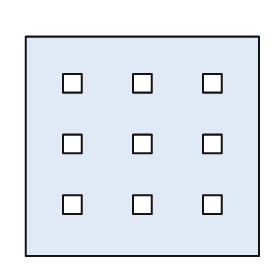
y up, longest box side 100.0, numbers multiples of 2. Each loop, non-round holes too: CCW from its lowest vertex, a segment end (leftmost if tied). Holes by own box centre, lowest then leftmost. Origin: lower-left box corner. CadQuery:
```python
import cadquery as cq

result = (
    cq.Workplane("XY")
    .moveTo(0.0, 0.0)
    .lineTo(100.0, 0.0)
    .lineTo(100.0, 94.0)
    .lineTo(0.0, 94.0)
    .close()
    .moveTo(16.0, 18.0)
    .lineTo(24.0, 18.0)
    .lineTo(24.0, 26.0)
    .lineTo(16.0, 26.0)
    .close()
    .moveTo(46.0, 18.0)
    .lineTo(54.0, 18.0)
    .lineTo(54.0, 26.0)
    .lineTo(46.0, 26.0)
    .close()
    .moveTo(76.0, 18.0)
    .lineTo(84.0, 18.0)
    .lineTo(84.0, 26.0)
    .lineTo(76.0, 26.0)
    .close()
    .moveTo(16.0, 44.0)
    .lineTo(24.0, 44.0)
    .lineTo(24.0, 52.0)
    .lineTo(16.0, 52.0)
    .close()
    .moveTo(46.0, 44.0)
    .lineTo(54.0, 44.0)
    .lineTo(54.0, 52.0)
    .lineTo(46.0, 52.0)
    .close()
    .moveTo(76.0, 44.0)
    .lineTo(84.0, 44.0)
    .lineTo(84.0, 52.0)
    .lineTo(76.0, 52.0)
    .close()
    .moveTo(16.0, 70.0)
    .lineTo(24.0, 70.0)
    .lineTo(24.0, 78.0)
    .lineTo(16.0, 78.0)
    .close()
    .moveTo(46.0, 70.0)
    .lineTo(54.0, 70.0)
    .lineTo(54.0, 78.0)
    .lineTo(46.0, 78.0)
    .close()
    .moveTo(76.0, 70.0)
    .lineTo(84.0, 70.0)
    .lineTo(84.0, 78.0)
    .lineTo(76.0, 78.0)
    .close()
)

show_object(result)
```